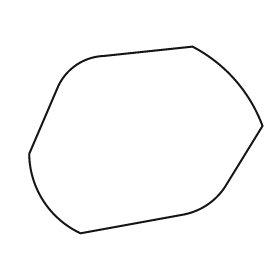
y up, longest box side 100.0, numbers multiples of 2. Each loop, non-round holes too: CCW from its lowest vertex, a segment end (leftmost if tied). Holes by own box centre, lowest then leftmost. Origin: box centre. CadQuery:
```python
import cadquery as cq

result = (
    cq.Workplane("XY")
    .moveTo(-28.0, -40.0)
    .lineTo(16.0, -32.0)
    .threePointArc((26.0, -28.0), (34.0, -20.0))
    .lineTo(50.0, 6.0)
    .threePointArc((38.0, 26.0), (20.0, 40.0))
    .lineTo(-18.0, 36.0)
    .threePointArc((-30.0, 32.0), (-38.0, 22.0))
    .lineTo(-50.0, -6.0)
    .threePointArc((-44.0, -26.0), (-28.0, -40.0))
    .close()
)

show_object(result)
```